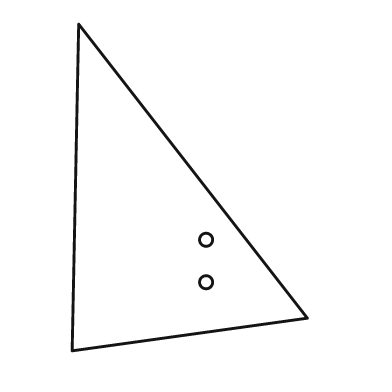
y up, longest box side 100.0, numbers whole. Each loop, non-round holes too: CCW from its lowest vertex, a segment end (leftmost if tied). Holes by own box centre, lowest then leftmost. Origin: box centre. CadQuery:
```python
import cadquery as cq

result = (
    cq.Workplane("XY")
    .moveTo(-36.0, -50.0)
    .lineTo(36.0, -40.0)
    .lineTo(-34.0, 50.0)
    .close()
    .moveTo(5.0, -29.0)
    .circle(2.0)
    .moveTo(5.0, -16.0)
    .circle(2.0)
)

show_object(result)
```